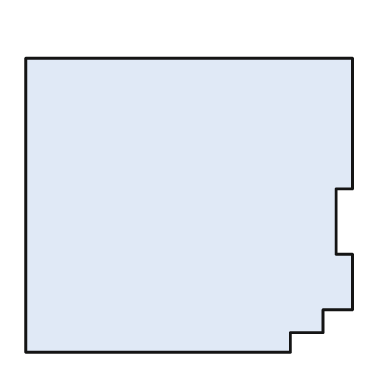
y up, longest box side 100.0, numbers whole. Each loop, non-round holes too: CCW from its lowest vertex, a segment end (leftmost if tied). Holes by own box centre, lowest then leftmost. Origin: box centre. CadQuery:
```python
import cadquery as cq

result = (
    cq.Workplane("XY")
    .moveTo(-50.0, -45.0)
    .lineTo(31.0, -45.0)
    .lineTo(31.0, -39.0)
    .lineTo(41.0, -39.0)
    .lineTo(41.0, -32.0)
    .lineTo(50.0, -32.0)
    .lineTo(50.0, -15.0)
    .lineTo(45.0, -15.0)
    .lineTo(45.0, 5.0)
    .lineTo(50.0, 5.0)
    .lineTo(50.0, 45.0)
    .lineTo(-50.0, 45.0)
    .close()
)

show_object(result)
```